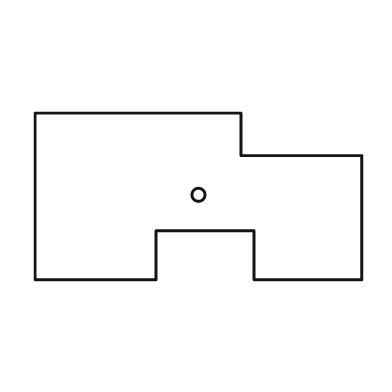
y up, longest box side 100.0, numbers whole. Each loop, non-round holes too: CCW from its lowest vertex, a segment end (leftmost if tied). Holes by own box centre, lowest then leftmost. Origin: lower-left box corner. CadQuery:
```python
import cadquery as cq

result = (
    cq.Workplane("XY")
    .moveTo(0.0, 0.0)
    .lineTo(37.0, 0.0)
    .lineTo(37.0, 15.0)
    .lineTo(67.0, 15.0)
    .lineTo(67.0, 0.0)
    .lineTo(100.0, 0.0)
    .lineTo(100.0, 38.0)
    .lineTo(63.0, 38.0)
    .lineTo(63.0, 51.0)
    .lineTo(0.0, 51.0)
    .close()
    .moveTo(50.0, 26.0)
    .circle(2.0)
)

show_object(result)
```